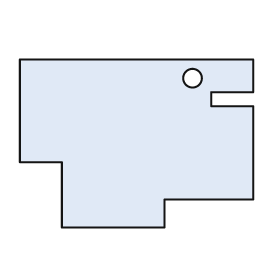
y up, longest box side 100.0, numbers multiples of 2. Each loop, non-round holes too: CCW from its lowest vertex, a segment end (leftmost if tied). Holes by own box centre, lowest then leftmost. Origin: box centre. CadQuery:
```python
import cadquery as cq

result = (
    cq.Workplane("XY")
    .moveTo(-32.0, -36.0)
    .lineTo(12.0, -36.0)
    .lineTo(12.0, -24.0)
    .lineTo(50.0, -24.0)
    .lineTo(50.0, 16.0)
    .lineTo(32.0, 16.0)
    .lineTo(32.0, 22.0)
    .lineTo(50.0, 22.0)
    .lineTo(50.0, 36.0)
    .lineTo(-50.0, 36.0)
    .lineTo(-50.0, -8.0)
    .lineTo(-32.0, -8.0)
    .close()
    .moveTo(24.0, 28.0)
    .circle(4.0)
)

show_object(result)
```